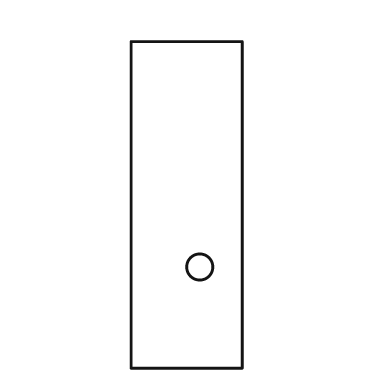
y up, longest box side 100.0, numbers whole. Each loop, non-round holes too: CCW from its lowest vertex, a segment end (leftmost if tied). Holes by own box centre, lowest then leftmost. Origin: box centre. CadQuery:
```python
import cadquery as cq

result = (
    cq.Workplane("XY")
    .moveTo(-17.0, -50.0)
    .lineTo(17.0, -50.0)
    .lineTo(17.0, 50.0)
    .lineTo(-17.0, 50.0)
    .close()
    .moveTo(4.0, -19.0)
    .circle(4.0)
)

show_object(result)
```